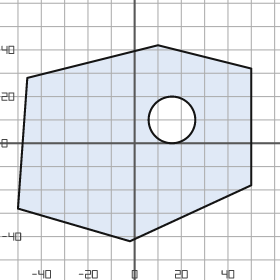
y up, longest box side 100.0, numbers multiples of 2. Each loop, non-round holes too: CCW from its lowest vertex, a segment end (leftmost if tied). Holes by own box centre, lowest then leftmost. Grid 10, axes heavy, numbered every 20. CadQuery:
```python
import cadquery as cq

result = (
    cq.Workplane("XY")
    .moveTo(-2.0, -42.0)
    .lineTo(50.0, -18.0)
    .lineTo(50.0, 32.0)
    .lineTo(10.0, 42.0)
    .lineTo(-46.0, 28.0)
    .lineTo(-50.0, -28.0)
    .close()
    .moveTo(16.0, 10.0)
    .circle(10.0)
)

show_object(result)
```